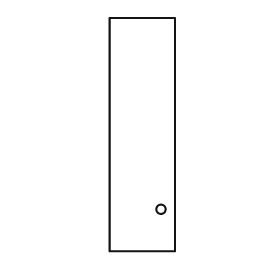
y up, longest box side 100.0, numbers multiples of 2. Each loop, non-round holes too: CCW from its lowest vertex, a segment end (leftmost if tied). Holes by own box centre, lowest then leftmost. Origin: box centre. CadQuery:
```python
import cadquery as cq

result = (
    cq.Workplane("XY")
    .moveTo(-14.0, -50.0)
    .lineTo(14.0, -50.0)
    .lineTo(14.0, 50.0)
    .lineTo(-14.0, 50.0)
    .close()
    .moveTo(8.0, -32.0)
    .circle(2.0)
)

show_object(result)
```